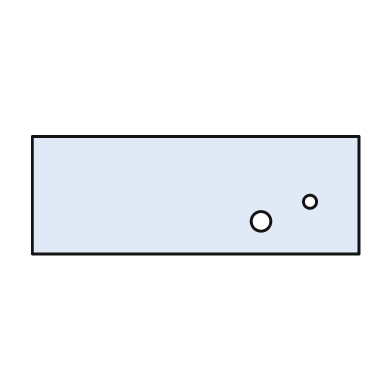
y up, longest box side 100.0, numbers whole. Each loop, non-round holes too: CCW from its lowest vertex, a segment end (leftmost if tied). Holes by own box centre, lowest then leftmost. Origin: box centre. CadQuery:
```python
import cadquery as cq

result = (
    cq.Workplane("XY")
    .moveTo(-50.0, -18.0)
    .lineTo(50.0, -18.0)
    .lineTo(50.0, 18.0)
    .lineTo(-50.0, 18.0)
    .close()
    .moveTo(20.0, -8.0)
    .circle(3.0)
    .moveTo(35.0, -2.0)
    .circle(2.0)
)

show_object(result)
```